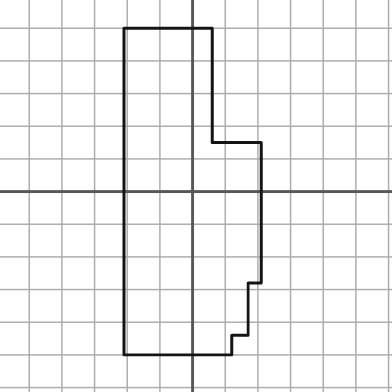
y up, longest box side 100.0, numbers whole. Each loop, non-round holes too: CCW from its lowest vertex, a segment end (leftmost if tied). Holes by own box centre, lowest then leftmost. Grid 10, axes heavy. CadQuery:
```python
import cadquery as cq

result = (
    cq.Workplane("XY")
    .moveTo(-21.0, -50.0)
    .lineTo(12.0, -50.0)
    .lineTo(12.0, -44.0)
    .lineTo(17.0, -44.0)
    .lineTo(17.0, -28.0)
    .lineTo(21.0, -28.0)
    .lineTo(21.0, 15.0)
    .lineTo(6.0, 15.0)
    .lineTo(6.0, 50.0)
    .lineTo(-21.0, 50.0)
    .close()
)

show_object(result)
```